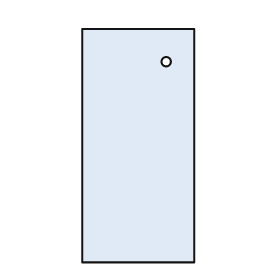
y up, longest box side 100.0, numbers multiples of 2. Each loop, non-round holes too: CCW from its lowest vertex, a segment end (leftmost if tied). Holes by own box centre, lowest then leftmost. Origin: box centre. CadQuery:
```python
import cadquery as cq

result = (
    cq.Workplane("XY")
    .moveTo(-24.0, -50.0)
    .lineTo(24.0, -50.0)
    .lineTo(24.0, 50.0)
    .lineTo(-24.0, 50.0)
    .close()
    .moveTo(12.0, 36.0)
    .circle(2.0)
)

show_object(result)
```